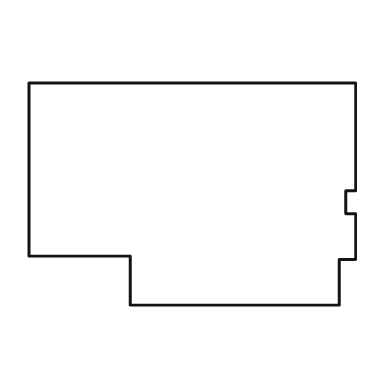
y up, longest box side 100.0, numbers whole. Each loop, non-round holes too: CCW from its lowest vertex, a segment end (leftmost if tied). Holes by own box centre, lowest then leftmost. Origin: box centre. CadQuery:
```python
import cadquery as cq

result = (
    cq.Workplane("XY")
    .moveTo(-19.0, -34.0)
    .lineTo(45.0, -34.0)
    .lineTo(45.0, -20.0)
    .lineTo(50.0, -20.0)
    .lineTo(50.0, -6.0)
    .lineTo(47.0, -6.0)
    .lineTo(47.0, 1.0)
    .lineTo(50.0, 1.0)
    .lineTo(50.0, 34.0)
    .lineTo(-50.0, 34.0)
    .lineTo(-50.0, -19.0)
    .lineTo(-19.0, -19.0)
    .close()
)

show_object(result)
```